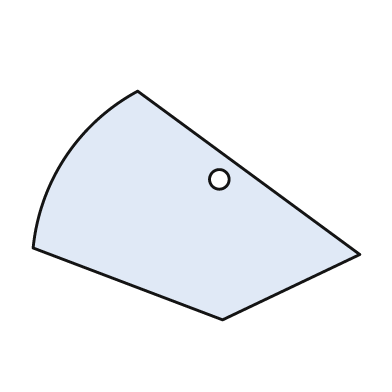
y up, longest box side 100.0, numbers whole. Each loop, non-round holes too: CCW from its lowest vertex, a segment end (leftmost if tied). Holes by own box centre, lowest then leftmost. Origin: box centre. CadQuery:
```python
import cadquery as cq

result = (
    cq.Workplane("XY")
    .moveTo(8.0, -35.0)
    .lineTo(50.0, -15.0)
    .lineTo(-18.0, 35.0)
    .threePointArc((-40.0, 15.0), (-50.0, -13.0))
    .close()
    .moveTo(7.0, 8.0)
    .circle(3.0)
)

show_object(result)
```